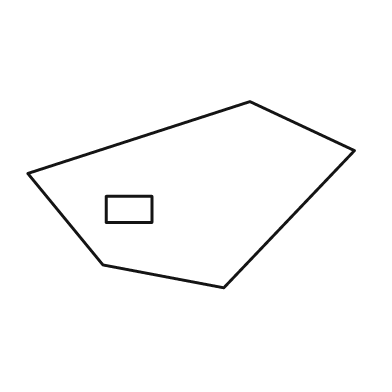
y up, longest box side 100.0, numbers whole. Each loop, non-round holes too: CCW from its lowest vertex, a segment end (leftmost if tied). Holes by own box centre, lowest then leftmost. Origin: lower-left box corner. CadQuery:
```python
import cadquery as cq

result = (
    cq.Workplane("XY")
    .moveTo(60.0, 0.0)
    .lineTo(100.0, 42.0)
    .lineTo(68.0, 57.0)
    .lineTo(0.0, 35.0)
    .lineTo(23.0, 7.0)
    .close()
    .moveTo(24.0, 20.0)
    .lineTo(38.0, 20.0)
    .lineTo(38.0, 28.0)
    .lineTo(24.0, 28.0)
    .close()
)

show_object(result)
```